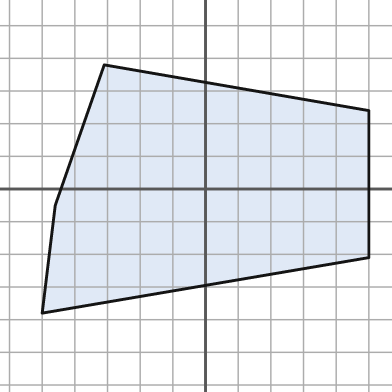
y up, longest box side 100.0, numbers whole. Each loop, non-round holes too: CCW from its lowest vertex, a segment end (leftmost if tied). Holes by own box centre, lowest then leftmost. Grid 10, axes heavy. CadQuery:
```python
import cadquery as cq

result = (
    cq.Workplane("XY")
    .moveTo(-50.0, -38.0)
    .lineTo(50.0, -21.0)
    .lineTo(50.0, 24.0)
    .lineTo(-31.0, 38.0)
    .lineTo(-46.0, -5.0)
    .close()
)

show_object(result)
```